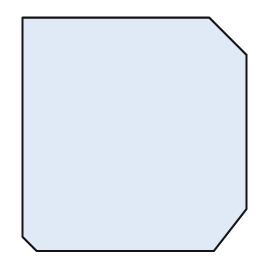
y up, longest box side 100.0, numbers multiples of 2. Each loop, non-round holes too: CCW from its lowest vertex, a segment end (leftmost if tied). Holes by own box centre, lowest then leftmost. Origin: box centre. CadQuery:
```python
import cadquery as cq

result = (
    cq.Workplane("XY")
    .moveTo(-42.0, -50.0)
    .lineTo(34.0, -50.0)
    .lineTo(48.0, -32.0)
    .lineTo(48.0, 34.0)
    .lineTo(32.0, 50.0)
    .lineTo(-48.0, 50.0)
    .lineTo(-48.0, -44.0)
    .close()
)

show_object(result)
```